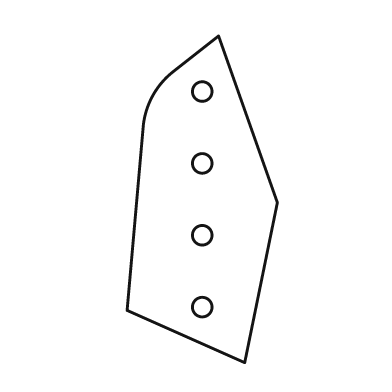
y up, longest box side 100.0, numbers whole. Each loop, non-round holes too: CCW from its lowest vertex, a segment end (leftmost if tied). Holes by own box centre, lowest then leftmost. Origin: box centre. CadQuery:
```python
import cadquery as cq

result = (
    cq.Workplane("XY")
    .moveTo(13.0, -50.0)
    .lineTo(23.0, -1.0)
    .lineTo(5.0, 50.0)
    .lineTo(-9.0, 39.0)
    .threePointArc((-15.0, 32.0), (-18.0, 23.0))
    .lineTo(-23.0, -34.0)
    .close()
    .moveTo(0.0, -33.0)
    .circle(3.0)
    .moveTo(0.0, -11.0)
    .circle(3.0)
    .moveTo(0.0, 11.0)
    .circle(3.0)
    .moveTo(0.0, 33.0)
    .circle(3.0)
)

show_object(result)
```